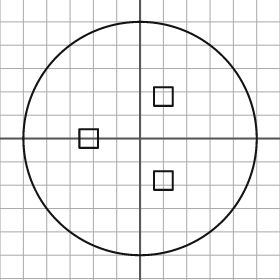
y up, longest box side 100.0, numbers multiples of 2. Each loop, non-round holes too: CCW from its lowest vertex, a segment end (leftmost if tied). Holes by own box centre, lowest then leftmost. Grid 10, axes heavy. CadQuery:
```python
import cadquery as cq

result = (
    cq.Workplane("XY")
    .moveTo(0.0, 0.0)
    .circle(50.0)
    .moveTo(6.0, -22.0)
    .lineTo(14.0, -22.0)
    .lineTo(14.0, -14.0)
    .lineTo(6.0, -14.0)
    .close()
    .moveTo(-26.0, -4.0)
    .lineTo(-18.0, -4.0)
    .lineTo(-18.0, 4.0)
    .lineTo(-26.0, 4.0)
    .close()
    .moveTo(6.0, 14.0)
    .lineTo(14.0, 14.0)
    .lineTo(14.0, 22.0)
    .lineTo(6.0, 22.0)
    .close()
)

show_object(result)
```